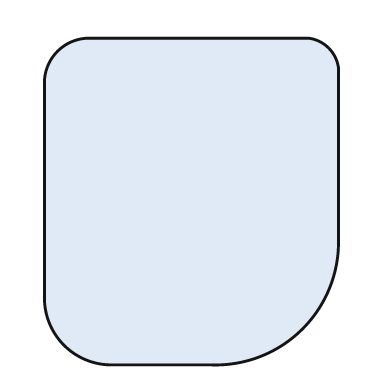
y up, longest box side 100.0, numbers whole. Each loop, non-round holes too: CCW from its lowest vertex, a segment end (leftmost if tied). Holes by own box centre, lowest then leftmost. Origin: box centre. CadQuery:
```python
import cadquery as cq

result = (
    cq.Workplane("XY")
    .moveTo(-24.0, -50.0)
    .lineTo(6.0, -50.0)
    .threePointArc((34.0, -39.0), (45.0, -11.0))
    .lineTo(45.0, 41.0)
    .threePointArc((42.0, 47.0), (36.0, 50.0))
    .lineTo(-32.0, 50.0)
    .threePointArc((-41.0, 46.0), (-45.0, 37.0))
    .lineTo(-45.0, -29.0)
    .threePointArc((-39.0, -44.0), (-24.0, -50.0))
    .close()
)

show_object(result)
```